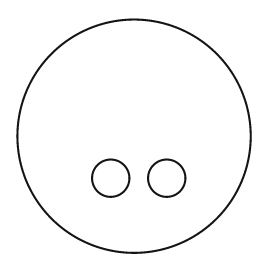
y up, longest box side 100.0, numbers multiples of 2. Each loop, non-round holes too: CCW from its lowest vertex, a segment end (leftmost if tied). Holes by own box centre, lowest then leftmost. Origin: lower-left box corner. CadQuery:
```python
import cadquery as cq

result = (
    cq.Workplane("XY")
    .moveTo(50.0, 50.0)
    .circle(50.0)
    .moveTo(40.0, 32.0)
    .circle(8.0)
    .moveTo(64.0, 32.0)
    .circle(8.0)
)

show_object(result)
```